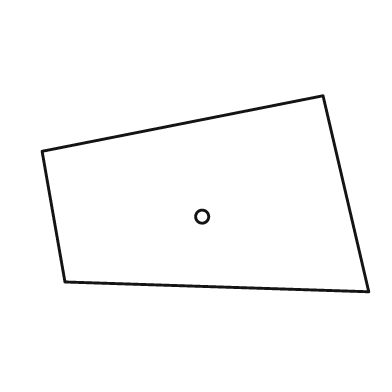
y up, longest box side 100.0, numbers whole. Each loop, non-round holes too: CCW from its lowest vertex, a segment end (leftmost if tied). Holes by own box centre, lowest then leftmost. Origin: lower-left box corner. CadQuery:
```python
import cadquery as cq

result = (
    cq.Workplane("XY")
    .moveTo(100.0, 0.0)
    .lineTo(86.0, 60.0)
    .lineTo(0.0, 43.0)
    .lineTo(7.0, 3.0)
    .close()
    .moveTo(49.0, 23.0)
    .circle(2.0)
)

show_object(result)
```